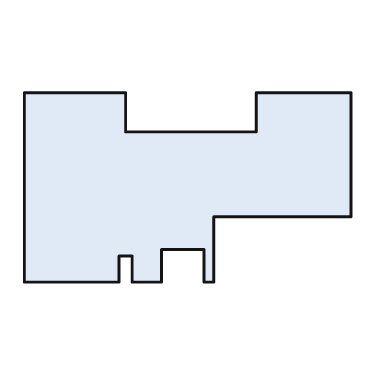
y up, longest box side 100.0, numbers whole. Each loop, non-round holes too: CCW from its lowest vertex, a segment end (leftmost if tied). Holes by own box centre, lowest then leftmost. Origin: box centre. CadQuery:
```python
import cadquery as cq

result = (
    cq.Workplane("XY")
    .moveTo(-50.0, -29.0)
    .lineTo(-21.0, -29.0)
    .lineTo(-21.0, -21.0)
    .lineTo(-17.0, -21.0)
    .lineTo(-17.0, -29.0)
    .lineTo(-8.0, -29.0)
    .lineTo(-8.0, -19.0)
    .lineTo(5.0, -19.0)
    .lineTo(5.0, -29.0)
    .lineTo(8.0, -29.0)
    .lineTo(8.0, -9.0)
    .lineTo(50.0, -9.0)
    .lineTo(50.0, 29.0)
    .lineTo(21.0, 29.0)
    .lineTo(21.0, 17.0)
    .lineTo(-19.0, 17.0)
    .lineTo(-19.0, 29.0)
    .lineTo(-50.0, 29.0)
    .close()
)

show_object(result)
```